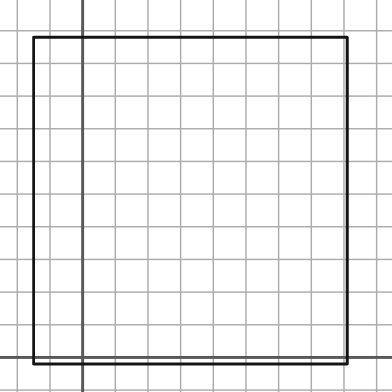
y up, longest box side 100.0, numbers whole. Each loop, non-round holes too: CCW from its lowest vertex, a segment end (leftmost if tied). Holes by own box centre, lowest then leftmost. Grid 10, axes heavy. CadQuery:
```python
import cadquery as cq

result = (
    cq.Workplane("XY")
    .moveTo(-15.0, -2.0)
    .lineTo(81.0, -2.0)
    .lineTo(81.0, 98.0)
    .lineTo(-15.0, 98.0)
    .close()
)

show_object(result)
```